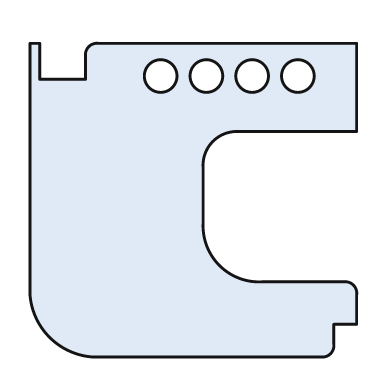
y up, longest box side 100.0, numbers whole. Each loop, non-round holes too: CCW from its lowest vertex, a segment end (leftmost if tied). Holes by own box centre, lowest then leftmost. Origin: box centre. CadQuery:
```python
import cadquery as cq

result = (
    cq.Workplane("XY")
    .moveTo(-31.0, -48.0)
    .lineTo(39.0, -48.0)
    .threePointArc((42.0, -47.0), (43.0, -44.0))
    .lineTo(43.0, -38.0)
    .lineTo(50.0, -38.0)
    .lineTo(50.0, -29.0)
    .threePointArc((49.0, -26.0), (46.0, -25.0))
    .lineTo(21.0, -25.0)
    .threePointArc((8.0, -20.0), (3.0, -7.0))
    .lineTo(3.0, 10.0)
    .threePointArc((6.0, 18.0), (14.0, 21.0))
    .lineTo(50.0, 21.0)
    .lineTo(50.0, 48.0)
    .lineTo(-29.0, 48.0)
    .threePointArc((-32.0, 47.0), (-33.0, 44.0))
    .lineTo(-33.0, 37.0)
    .lineTo(-47.0, 37.0)
    .lineTo(-47.0, 48.0)
    .lineTo(-50.0, 48.0)
    .lineTo(-50.0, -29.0)
    .threePointArc((-44.0, -42.0), (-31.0, -48.0))
    .close()
    .moveTo(-10.0, 38.0)
    .circle(5.0)
    .moveTo(4.0, 38.0)
    .circle(5.0)
    .moveTo(18.0, 38.0)
    .circle(5.0)
    .moveTo(32.0, 38.0)
    .circle(5.0)
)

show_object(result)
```